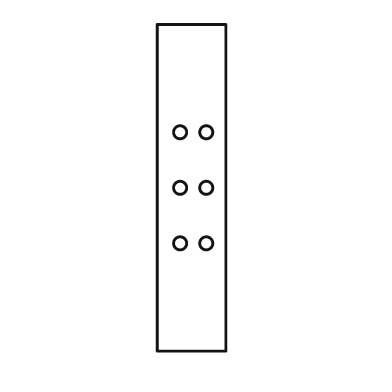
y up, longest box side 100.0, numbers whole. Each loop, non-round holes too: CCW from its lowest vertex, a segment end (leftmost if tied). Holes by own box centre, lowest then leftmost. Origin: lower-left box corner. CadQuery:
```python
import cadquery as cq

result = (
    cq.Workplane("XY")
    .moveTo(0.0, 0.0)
    .lineTo(21.0, 0.0)
    .lineTo(21.0, 100.0)
    .lineTo(0.0, 100.0)
    .close()
    .moveTo(7.0, 33.0)
    .circle(2.0)
    .moveTo(15.0, 33.0)
    .circle(2.0)
    .moveTo(7.0, 50.0)
    .circle(2.0)
    .moveTo(15.0, 50.0)
    .circle(2.0)
    .moveTo(7.0, 67.0)
    .circle(2.0)
    .moveTo(15.0, 67.0)
    .circle(2.0)
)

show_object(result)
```